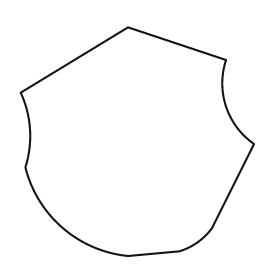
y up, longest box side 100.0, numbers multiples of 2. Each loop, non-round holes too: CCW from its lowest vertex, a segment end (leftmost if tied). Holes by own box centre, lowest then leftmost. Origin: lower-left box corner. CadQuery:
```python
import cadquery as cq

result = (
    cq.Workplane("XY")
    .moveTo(46.0, 0.0)
    .lineTo(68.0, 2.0)
    .threePointArc((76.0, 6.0), (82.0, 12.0))
    .lineTo(100.0, 48.0)
    .threePointArc((88.0, 64.0), (88.0, 84.0))
    .lineTo(46.0, 98.0)
    .lineTo(0.0, 70.0)
    .threePointArc((4.0, 54.0), (2.0, 38.0))
    .threePointArc((18.0, 12.0), (46.0, 0.0))
    .close()
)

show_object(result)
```